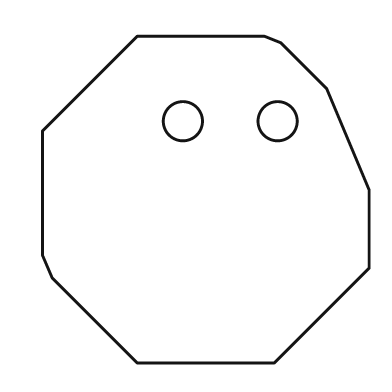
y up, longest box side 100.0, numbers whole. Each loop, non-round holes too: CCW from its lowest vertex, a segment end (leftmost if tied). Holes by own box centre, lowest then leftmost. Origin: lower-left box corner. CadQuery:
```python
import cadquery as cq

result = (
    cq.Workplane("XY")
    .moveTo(29.0, 0.0)
    .lineTo(71.0, 0.0)
    .lineTo(100.0, 29.0)
    .lineTo(100.0, 53.0)
    .lineTo(87.0, 84.0)
    .lineTo(73.0, 98.0)
    .lineTo(68.0, 100.0)
    .lineTo(29.0, 100.0)
    .lineTo(0.0, 71.0)
    .lineTo(0.0, 33.0)
    .lineTo(3.0, 26.0)
    .close()
    .moveTo(43.0, 74.0)
    .circle(6.0)
    .moveTo(72.0, 74.0)
    .circle(6.0)
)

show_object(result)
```